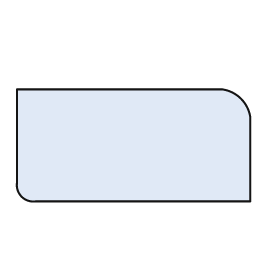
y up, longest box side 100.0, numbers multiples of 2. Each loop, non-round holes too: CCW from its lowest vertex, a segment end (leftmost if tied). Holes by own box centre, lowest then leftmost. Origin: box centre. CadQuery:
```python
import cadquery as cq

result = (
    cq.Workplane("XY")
    .moveTo(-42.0, -24.0)
    .lineTo(50.0, -24.0)
    .lineTo(50.0, 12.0)
    .threePointArc((46.0, 20.0), (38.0, 24.0))
    .lineTo(-50.0, 24.0)
    .lineTo(-50.0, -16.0)
    .threePointArc((-48.0, -22.0), (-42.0, -24.0))
    .close()
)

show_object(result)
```